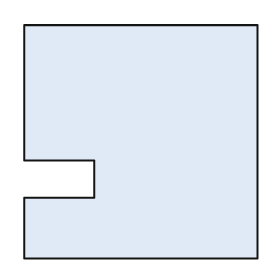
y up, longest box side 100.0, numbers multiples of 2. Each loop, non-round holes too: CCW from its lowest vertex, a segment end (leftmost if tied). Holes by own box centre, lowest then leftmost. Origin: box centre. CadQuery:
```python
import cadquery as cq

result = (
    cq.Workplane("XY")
    .moveTo(-50.0, -50.0)
    .lineTo(50.0, -50.0)
    .lineTo(50.0, 50.0)
    .lineTo(-50.0, 50.0)
    .lineTo(-50.0, -8.0)
    .lineTo(-20.0, -8.0)
    .lineTo(-20.0, -24.0)
    .lineTo(-50.0, -24.0)
    .close()
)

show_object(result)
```